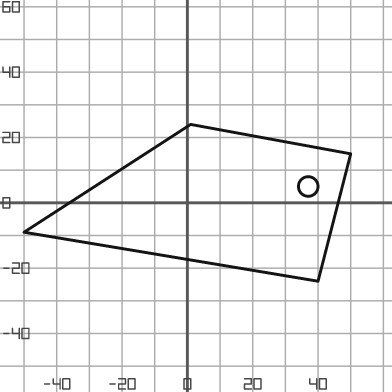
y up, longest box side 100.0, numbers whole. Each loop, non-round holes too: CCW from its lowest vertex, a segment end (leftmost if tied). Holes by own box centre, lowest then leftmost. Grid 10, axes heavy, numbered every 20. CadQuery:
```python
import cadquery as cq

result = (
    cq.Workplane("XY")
    .moveTo(40.0, -24.0)
    .lineTo(50.0, 15.0)
    .lineTo(1.0, 24.0)
    .lineTo(-50.0, -9.0)
    .close()
    .moveTo(37.0, 5.0)
    .circle(3.0)
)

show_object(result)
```